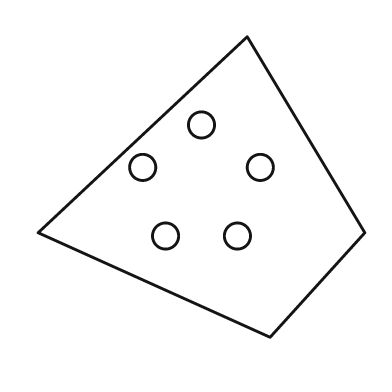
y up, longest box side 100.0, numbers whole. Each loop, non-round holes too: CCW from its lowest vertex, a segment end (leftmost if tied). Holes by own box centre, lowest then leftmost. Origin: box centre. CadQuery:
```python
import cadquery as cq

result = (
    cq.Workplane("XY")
    .moveTo(21.0, -46.0)
    .lineTo(50.0, -14.0)
    .lineTo(14.0, 46.0)
    .lineTo(-50.0, -14.0)
    .close()
    .moveTo(-11.0, -15.0)
    .circle(4.0)
    .moveTo(11.0, -15.0)
    .circle(4.0)
    .moveTo(-18.0, 6.0)
    .circle(4.0)
    .moveTo(18.0, 6.0)
    .circle(4.0)
    .moveTo(0.0, 19.0)
    .circle(4.0)
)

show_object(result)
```